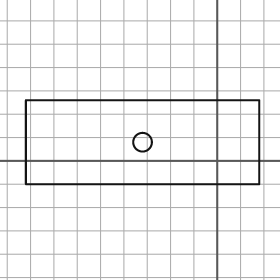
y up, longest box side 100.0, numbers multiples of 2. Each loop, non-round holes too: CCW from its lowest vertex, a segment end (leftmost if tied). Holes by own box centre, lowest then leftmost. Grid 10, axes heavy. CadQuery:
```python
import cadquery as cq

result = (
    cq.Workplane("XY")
    .moveTo(-82.0, -10.0)
    .lineTo(18.0, -10.0)
    .lineTo(18.0, 26.0)
    .lineTo(-82.0, 26.0)
    .close()
    .moveTo(-32.0, 8.0)
    .circle(4.0)
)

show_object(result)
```